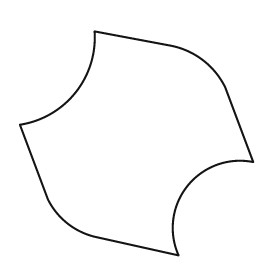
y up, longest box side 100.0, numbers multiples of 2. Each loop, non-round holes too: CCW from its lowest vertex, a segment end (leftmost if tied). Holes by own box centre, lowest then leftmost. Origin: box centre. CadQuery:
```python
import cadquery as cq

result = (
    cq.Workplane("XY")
    .moveTo(18.0, -48.0)
    .threePointArc((22.0, -18.0), (50.0, -8.0))
    .lineTo(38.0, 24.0)
    .threePointArc((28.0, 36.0), (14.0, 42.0))
    .lineTo(-18.0, 48.0)
    .threePointArc((-26.0, 22.0), (-50.0, 8.0))
    .lineTo(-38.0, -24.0)
    .threePointArc((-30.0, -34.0), (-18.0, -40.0))
    .close()
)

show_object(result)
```